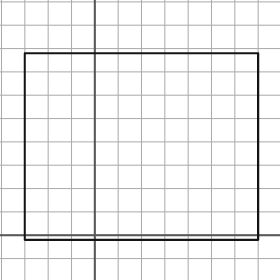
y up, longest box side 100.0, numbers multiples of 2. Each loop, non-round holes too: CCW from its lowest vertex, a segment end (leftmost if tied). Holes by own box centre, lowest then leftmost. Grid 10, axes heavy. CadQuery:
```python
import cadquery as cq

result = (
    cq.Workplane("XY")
    .moveTo(-30.0, -2.0)
    .lineTo(70.0, -2.0)
    .lineTo(70.0, 78.0)
    .lineTo(-30.0, 78.0)
    .close()
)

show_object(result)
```